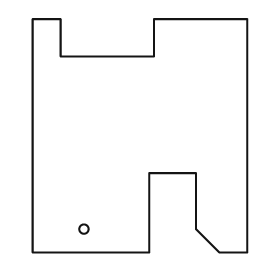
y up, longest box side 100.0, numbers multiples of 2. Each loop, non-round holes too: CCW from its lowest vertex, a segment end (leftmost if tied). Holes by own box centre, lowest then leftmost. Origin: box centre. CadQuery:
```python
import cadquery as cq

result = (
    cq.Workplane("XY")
    .moveTo(-46.0, -50.0)
    .lineTo(4.0, -50.0)
    .lineTo(4.0, -16.0)
    .lineTo(24.0, -16.0)
    .lineTo(24.0, -40.0)
    .lineTo(34.0, -50.0)
    .lineTo(46.0, -50.0)
    .lineTo(46.0, 50.0)
    .lineTo(6.0, 50.0)
    .lineTo(6.0, 34.0)
    .lineTo(-34.0, 34.0)
    .lineTo(-34.0, 50.0)
    .lineTo(-46.0, 50.0)
    .close()
    .moveTo(-24.0, -40.0)
    .circle(2.0)
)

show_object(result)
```